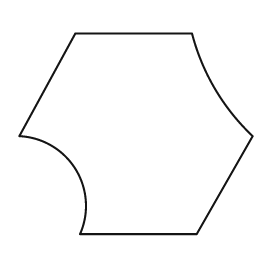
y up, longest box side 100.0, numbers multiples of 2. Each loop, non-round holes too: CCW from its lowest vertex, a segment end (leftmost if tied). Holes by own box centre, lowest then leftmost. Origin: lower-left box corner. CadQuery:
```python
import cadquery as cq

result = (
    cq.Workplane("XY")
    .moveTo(26.0, 0.0)
    .lineTo(76.0, 0.0)
    .lineTo(100.0, 42.0)
    .threePointArc((84.0, 62.0), (74.0, 86.0))
    .lineTo(24.0, 86.0)
    .lineTo(0.0, 42.0)
    .threePointArc((24.0, 28.0), (26.0, 0.0))
    .close()
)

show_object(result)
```